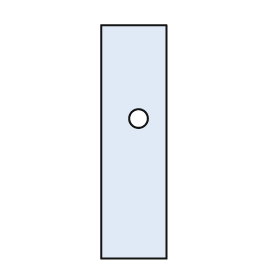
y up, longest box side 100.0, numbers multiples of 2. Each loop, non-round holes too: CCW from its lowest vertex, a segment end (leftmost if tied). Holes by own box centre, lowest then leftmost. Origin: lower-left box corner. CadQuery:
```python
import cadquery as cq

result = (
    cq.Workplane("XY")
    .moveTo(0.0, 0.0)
    .lineTo(28.0, 0.0)
    .lineTo(28.0, 100.0)
    .lineTo(0.0, 100.0)
    .close()
    .moveTo(16.0, 60.0)
    .circle(4.0)
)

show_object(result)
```